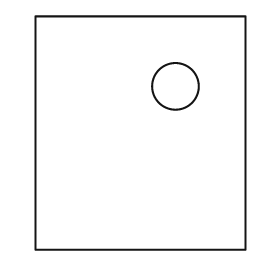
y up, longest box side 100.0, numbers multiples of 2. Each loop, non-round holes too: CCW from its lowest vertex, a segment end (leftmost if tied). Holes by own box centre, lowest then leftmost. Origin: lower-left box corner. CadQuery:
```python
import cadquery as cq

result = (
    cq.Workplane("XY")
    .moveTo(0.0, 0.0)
    .lineTo(90.0, 0.0)
    .lineTo(90.0, 100.0)
    .lineTo(0.0, 100.0)
    .close()
    .moveTo(60.0, 70.0)
    .circle(10.0)
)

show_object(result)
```